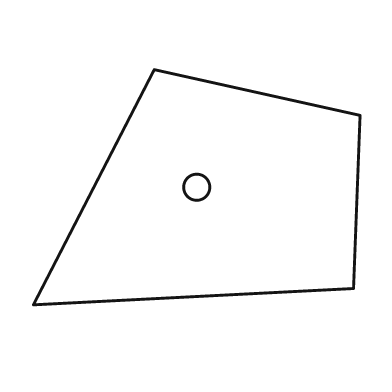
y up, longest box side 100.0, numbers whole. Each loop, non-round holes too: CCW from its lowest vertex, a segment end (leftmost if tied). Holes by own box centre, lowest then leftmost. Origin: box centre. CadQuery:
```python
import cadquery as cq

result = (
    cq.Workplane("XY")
    .moveTo(-50.0, -36.0)
    .lineTo(48.0, -31.0)
    .lineTo(50.0, 22.0)
    .lineTo(-13.0, 36.0)
    .close()
    .moveTo(0.0, 0.0)
    .circle(4.0)
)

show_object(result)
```